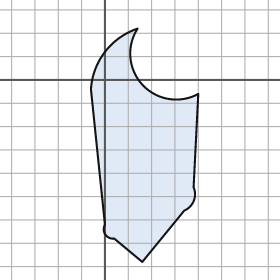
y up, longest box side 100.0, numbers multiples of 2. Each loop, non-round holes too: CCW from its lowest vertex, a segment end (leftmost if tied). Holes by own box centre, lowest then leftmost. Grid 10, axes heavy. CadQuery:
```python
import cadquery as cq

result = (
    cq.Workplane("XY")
    .moveTo(16.0, -78.0)
    .lineTo(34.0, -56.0)
    .threePointArc((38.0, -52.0), (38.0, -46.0))
    .lineTo(40.0, -6.0)
    .threePointArc((16.0, -2.0), (14.0, 22.0))
    .threePointArc((0.0, 12.0), (-6.0, -4.0))
    .lineTo(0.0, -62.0)
    .threePointArc((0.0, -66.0), (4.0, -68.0))
    .close()
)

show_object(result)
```